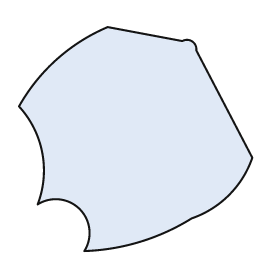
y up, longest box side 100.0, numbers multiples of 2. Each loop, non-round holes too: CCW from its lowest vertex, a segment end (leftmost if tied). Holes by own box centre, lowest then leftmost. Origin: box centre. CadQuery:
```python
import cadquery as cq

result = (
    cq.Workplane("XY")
    .moveTo(-22.0, -48.0)
    .threePointArc((2.0, -44.0), (24.0, -34.0))
    .threePointArc((40.0, -24.0), (50.0, -8.0))
    .lineTo(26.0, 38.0)
    .threePointArc((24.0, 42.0), (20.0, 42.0))
    .lineTo(-12.0, 48.0)
    .threePointArc((-34.0, 34.0), (-50.0, 14.0))
    .threePointArc((-40.0, -6.0), (-42.0, -28.0))
    .threePointArc((-24.0, -30.0), (-22.0, -48.0))
    .close()
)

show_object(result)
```